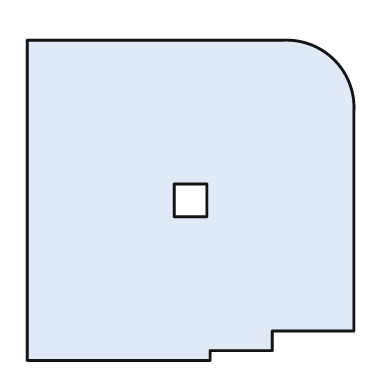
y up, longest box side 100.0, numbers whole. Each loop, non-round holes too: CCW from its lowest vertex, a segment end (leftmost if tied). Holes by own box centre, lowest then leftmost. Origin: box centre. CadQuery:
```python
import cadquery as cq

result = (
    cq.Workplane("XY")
    .moveTo(-50.0, -49.0)
    .lineTo(6.0, -49.0)
    .lineTo(6.0, -46.0)
    .lineTo(25.0, -46.0)
    .lineTo(25.0, -40.0)
    .lineTo(50.0, -40.0)
    .lineTo(50.0, 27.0)
    .threePointArc((44.0, 43.0), (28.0, 49.0))
    .lineTo(-50.0, 49.0)
    .close()
    .moveTo(-5.0, -5.0)
    .lineTo(5.0, -5.0)
    .lineTo(5.0, 5.0)
    .lineTo(-5.0, 5.0)
    .close()
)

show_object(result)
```